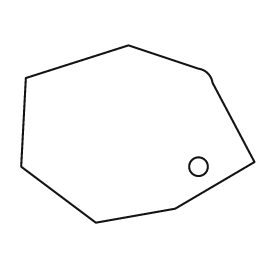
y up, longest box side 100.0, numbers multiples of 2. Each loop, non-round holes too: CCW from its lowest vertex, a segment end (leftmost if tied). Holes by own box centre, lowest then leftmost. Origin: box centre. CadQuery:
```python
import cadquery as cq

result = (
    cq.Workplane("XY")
    .moveTo(-18.0, -38.0)
    .lineTo(16.0, -32.0)
    .lineTo(50.0, -12.0)
    .lineTo(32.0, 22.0)
    .threePointArc((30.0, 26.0), (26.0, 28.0))
    .lineTo(-4.0, 38.0)
    .lineTo(-48.0, 24.0)
    .lineTo(-50.0, -14.0)
    .close()
    .moveTo(26.0, -14.0)
    .circle(4.0)
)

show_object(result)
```